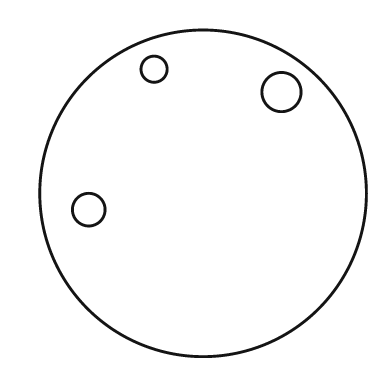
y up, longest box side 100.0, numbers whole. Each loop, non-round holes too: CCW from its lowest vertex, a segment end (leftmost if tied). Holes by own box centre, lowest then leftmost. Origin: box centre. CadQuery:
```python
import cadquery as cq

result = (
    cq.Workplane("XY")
    .moveTo(0.0, 0.0)
    .circle(50.0)
    .moveTo(-35.0, -5.0)
    .circle(5.0)
    .moveTo(24.0, 31.0)
    .circle(6.0)
    .moveTo(-15.0, 38.0)
    .circle(4.0)
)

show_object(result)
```